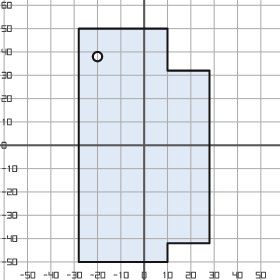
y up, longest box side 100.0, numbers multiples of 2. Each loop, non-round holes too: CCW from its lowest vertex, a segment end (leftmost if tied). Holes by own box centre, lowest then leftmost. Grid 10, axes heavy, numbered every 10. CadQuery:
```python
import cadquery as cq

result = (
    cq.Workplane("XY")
    .moveTo(-28.0, -50.0)
    .lineTo(10.0, -50.0)
    .lineTo(10.0, -42.0)
    .lineTo(28.0, -42.0)
    .lineTo(28.0, 32.0)
    .lineTo(10.0, 32.0)
    .lineTo(10.0, 50.0)
    .lineTo(-28.0, 50.0)
    .close()
    .moveTo(-20.0, 38.0)
    .circle(2.0)
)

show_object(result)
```